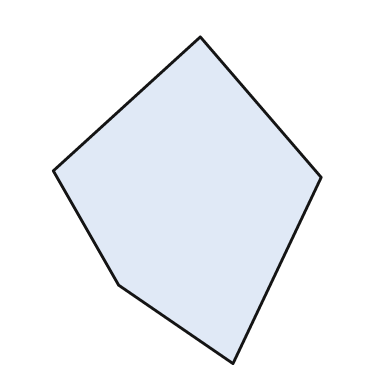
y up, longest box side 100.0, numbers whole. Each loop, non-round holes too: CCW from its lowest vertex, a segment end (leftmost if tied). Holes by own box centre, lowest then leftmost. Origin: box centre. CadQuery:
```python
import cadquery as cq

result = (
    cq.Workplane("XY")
    .moveTo(14.0, -50.0)
    .lineTo(41.0, 7.0)
    .lineTo(4.0, 50.0)
    .lineTo(-41.0, 9.0)
    .lineTo(-21.0, -26.0)
    .close()
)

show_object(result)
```